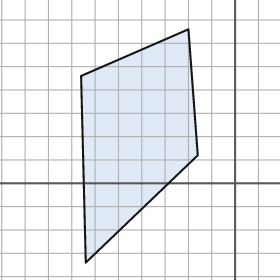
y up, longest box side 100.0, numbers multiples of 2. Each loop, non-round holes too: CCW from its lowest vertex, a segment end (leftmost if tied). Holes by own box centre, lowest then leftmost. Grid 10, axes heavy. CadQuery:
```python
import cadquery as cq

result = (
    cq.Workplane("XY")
    .moveTo(-64.0, -34.0)
    .lineTo(-16.0, 12.0)
    .lineTo(-20.0, 66.0)
    .lineTo(-66.0, 46.0)
    .close()
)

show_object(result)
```